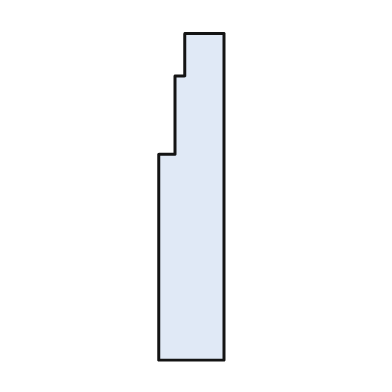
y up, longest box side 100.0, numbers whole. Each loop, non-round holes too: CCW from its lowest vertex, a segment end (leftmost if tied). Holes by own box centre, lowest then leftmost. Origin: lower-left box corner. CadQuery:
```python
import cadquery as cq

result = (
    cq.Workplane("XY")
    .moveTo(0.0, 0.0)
    .lineTo(20.0, 0.0)
    .lineTo(20.0, 100.0)
    .lineTo(8.0, 100.0)
    .lineTo(8.0, 87.0)
    .lineTo(5.0, 87.0)
    .lineTo(5.0, 63.0)
    .lineTo(0.0, 63.0)
    .close()
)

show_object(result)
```